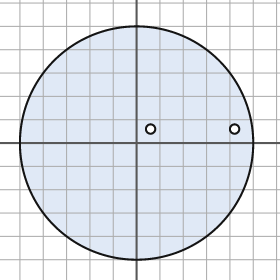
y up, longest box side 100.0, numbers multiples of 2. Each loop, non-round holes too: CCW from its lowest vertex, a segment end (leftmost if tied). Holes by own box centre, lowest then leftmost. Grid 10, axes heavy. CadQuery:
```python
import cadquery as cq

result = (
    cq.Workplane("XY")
    .moveTo(0.0, 0.0)
    .circle(50.0)
    .moveTo(6.0, 6.0)
    .circle(2.0)
    .moveTo(42.0, 6.0)
    .circle(2.0)
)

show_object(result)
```